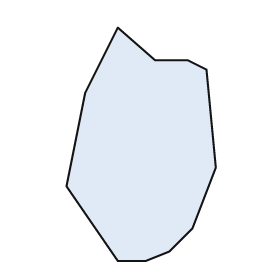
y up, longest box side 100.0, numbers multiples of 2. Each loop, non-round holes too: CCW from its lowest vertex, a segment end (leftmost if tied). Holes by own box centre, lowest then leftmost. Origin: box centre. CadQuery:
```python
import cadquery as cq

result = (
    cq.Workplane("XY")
    .moveTo(-10.0, -50.0)
    .lineTo(2.0, -50.0)
    .lineTo(12.0, -46.0)
    .lineTo(22.0, -36.0)
    .lineTo(32.0, -10.0)
    .lineTo(28.0, 32.0)
    .lineTo(20.0, 36.0)
    .lineTo(6.0, 36.0)
    .lineTo(-10.0, 50.0)
    .lineTo(-24.0, 22.0)
    .lineTo(-32.0, -18.0)
    .close()
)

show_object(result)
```